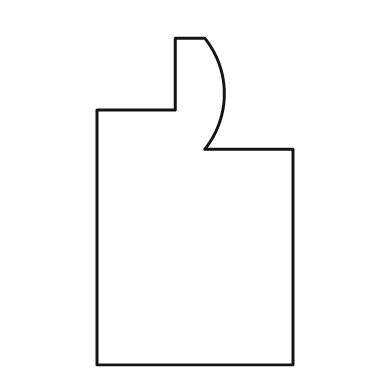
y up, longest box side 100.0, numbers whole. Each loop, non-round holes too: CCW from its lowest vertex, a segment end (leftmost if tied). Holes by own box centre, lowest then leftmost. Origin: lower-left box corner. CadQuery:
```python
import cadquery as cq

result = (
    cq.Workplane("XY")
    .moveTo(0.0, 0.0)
    .lineTo(60.0, 0.0)
    .lineTo(60.0, 66.0)
    .lineTo(33.0, 66.0)
    .threePointArc((39.0, 83.0), (33.0, 100.0))
    .lineTo(24.0, 100.0)
    .lineTo(24.0, 78.0)
    .lineTo(0.0, 78.0)
    .close()
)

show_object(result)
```